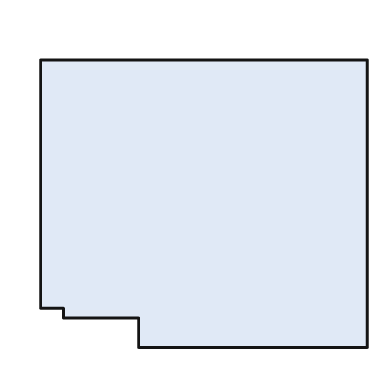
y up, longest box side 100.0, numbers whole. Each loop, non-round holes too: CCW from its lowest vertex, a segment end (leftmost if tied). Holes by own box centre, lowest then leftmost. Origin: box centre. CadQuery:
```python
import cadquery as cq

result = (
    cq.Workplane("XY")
    .moveTo(-20.0, -44.0)
    .lineTo(50.0, -44.0)
    .lineTo(50.0, 44.0)
    .lineTo(-50.0, 44.0)
    .lineTo(-50.0, -32.0)
    .lineTo(-43.0, -32.0)
    .lineTo(-43.0, -35.0)
    .lineTo(-20.0, -35.0)
    .close()
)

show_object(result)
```